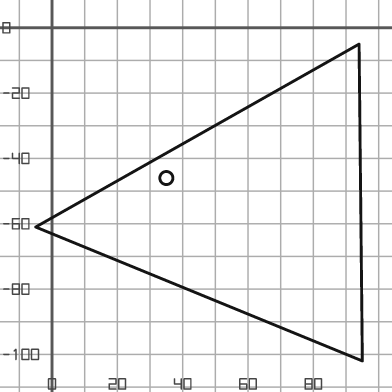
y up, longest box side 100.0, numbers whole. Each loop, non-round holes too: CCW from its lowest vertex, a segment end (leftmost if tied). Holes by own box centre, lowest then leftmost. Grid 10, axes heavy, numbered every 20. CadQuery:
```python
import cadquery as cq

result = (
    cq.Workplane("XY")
    .moveTo(95.0, -102.0)
    .lineTo(94.0, -5.0)
    .lineTo(-5.0, -61.0)
    .close()
    .moveTo(35.0, -46.0)
    .circle(2.0)
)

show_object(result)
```